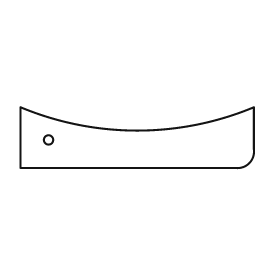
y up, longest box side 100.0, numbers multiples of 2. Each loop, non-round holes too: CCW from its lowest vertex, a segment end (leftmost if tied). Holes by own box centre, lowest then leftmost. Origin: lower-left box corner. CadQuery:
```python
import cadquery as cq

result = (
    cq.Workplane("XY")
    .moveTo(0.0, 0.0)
    .lineTo(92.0, 0.0)
    .threePointArc((98.0, 2.0), (100.0, 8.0))
    .lineTo(100.0, 26.0)
    .threePointArc((50.0, 16.0), (0.0, 26.0))
    .close()
    .moveTo(12.0, 12.0)
    .circle(2.0)
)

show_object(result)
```